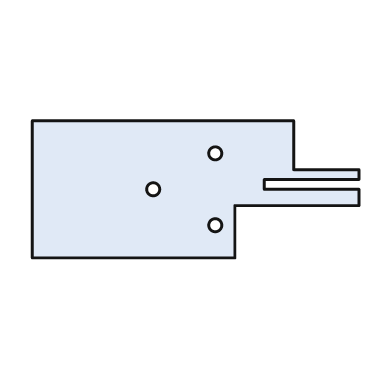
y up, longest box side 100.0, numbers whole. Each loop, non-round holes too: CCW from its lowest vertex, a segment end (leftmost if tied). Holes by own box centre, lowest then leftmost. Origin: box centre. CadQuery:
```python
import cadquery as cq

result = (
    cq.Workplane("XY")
    .moveTo(-50.0, -21.0)
    .lineTo(12.0, -21.0)
    .lineTo(12.0, -5.0)
    .lineTo(50.0, -5.0)
    .lineTo(50.0, 0.0)
    .lineTo(21.0, 0.0)
    .lineTo(21.0, 3.0)
    .lineTo(50.0, 3.0)
    .lineTo(50.0, 6.0)
    .lineTo(30.0, 6.0)
    .lineTo(30.0, 21.0)
    .lineTo(-50.0, 21.0)
    .close()
    .moveTo(6.0, -11.0)
    .circle(2.0)
    .moveTo(-13.0, 0.0)
    .circle(2.0)
    .moveTo(6.0, 11.0)
    .circle(2.0)
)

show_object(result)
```